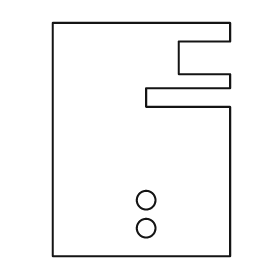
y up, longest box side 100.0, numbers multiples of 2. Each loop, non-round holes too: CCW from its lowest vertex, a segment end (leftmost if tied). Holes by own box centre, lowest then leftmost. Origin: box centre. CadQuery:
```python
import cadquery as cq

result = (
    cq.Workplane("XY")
    .moveTo(-38.0, -50.0)
    .lineTo(38.0, -50.0)
    .lineTo(38.0, 14.0)
    .lineTo(2.0, 14.0)
    .lineTo(2.0, 22.0)
    .lineTo(38.0, 22.0)
    .lineTo(38.0, 28.0)
    .lineTo(16.0, 28.0)
    .lineTo(16.0, 42.0)
    .lineTo(38.0, 42.0)
    .lineTo(38.0, 50.0)
    .lineTo(-38.0, 50.0)
    .close()
    .moveTo(2.0, -38.0)
    .circle(4.0)
    .moveTo(2.0, -26.0)
    .circle(4.0)
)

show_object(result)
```